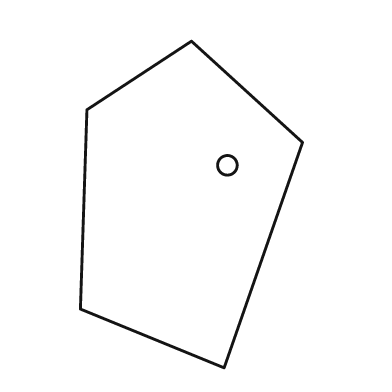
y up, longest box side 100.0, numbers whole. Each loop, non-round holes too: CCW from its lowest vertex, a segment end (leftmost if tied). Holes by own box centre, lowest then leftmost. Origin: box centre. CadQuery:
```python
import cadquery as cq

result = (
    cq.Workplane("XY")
    .moveTo(10.0, -50.0)
    .lineTo(34.0, 19.0)
    .lineTo(0.0, 50.0)
    .lineTo(-32.0, 29.0)
    .lineTo(-34.0, -32.0)
    .close()
    .moveTo(11.0, 12.0)
    .circle(3.0)
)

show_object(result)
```